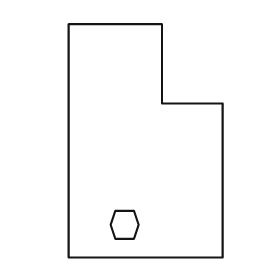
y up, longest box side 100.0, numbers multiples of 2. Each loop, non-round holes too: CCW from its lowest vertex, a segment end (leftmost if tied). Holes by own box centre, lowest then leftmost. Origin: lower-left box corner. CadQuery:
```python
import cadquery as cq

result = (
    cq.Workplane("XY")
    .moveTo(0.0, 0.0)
    .lineTo(66.0, 0.0)
    .lineTo(66.0, 66.0)
    .lineTo(40.0, 66.0)
    .lineTo(40.0, 100.0)
    .lineTo(0.0, 100.0)
    .close()
    .moveTo(20.0, 8.0)
    .lineTo(28.0, 8.0)
    .lineTo(30.0, 14.0)
    .lineTo(28.0, 20.0)
    .lineTo(20.0, 20.0)
    .lineTo(18.0, 14.0)
    .close()
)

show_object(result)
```